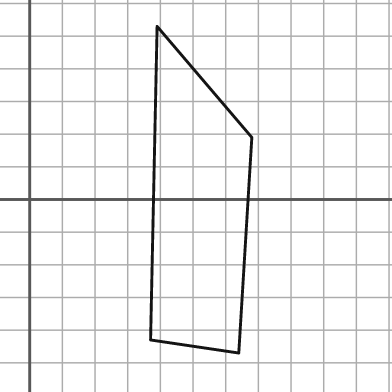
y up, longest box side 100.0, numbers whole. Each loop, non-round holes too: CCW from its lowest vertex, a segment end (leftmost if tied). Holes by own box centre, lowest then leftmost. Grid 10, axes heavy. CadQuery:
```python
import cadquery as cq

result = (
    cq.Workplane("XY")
    .moveTo(64.0, -47.0)
    .lineTo(68.0, 19.0)
    .lineTo(39.0, 53.0)
    .lineTo(37.0, -43.0)
    .close()
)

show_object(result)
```